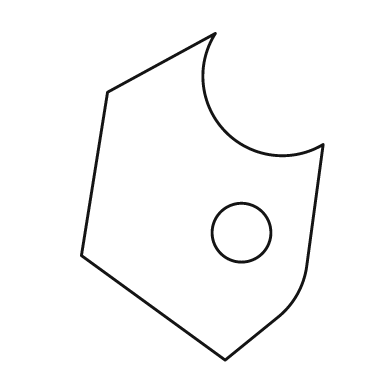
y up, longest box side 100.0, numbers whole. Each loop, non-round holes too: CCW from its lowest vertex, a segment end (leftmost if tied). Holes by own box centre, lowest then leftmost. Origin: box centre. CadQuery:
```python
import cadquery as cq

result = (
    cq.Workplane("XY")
    .moveTo(7.0, -50.0)
    .lineTo(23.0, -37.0)
    .threePointArc((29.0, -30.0), (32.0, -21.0))
    .lineTo(37.0, 16.0)
    .threePointArc((7.0, 20.0), (4.0, 50.0))
    .lineTo(-29.0, 32.0)
    .lineTo(-37.0, -18.0)
    .close()
    .moveTo(12.0, -11.0)
    .circle(9.0)
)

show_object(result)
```